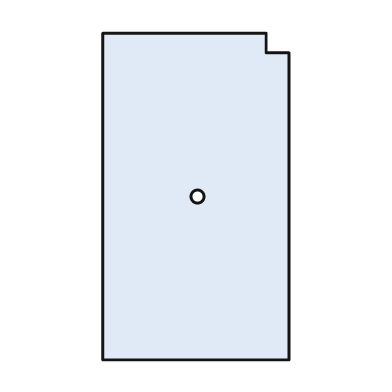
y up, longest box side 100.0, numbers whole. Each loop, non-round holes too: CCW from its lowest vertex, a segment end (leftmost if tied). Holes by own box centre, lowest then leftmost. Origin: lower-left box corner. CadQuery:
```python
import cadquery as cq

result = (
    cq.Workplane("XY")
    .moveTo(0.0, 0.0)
    .lineTo(57.0, 0.0)
    .lineTo(57.0, 94.0)
    .lineTo(50.0, 94.0)
    .lineTo(50.0, 100.0)
    .lineTo(0.0, 100.0)
    .close()
    .moveTo(29.0, 50.0)
    .circle(2.0)
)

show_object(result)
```